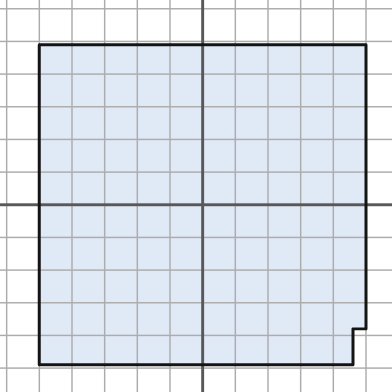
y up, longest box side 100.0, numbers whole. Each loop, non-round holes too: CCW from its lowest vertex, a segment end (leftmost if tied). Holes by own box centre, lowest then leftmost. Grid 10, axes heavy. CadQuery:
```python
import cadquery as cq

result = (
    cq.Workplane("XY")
    .moveTo(-50.0, -49.0)
    .lineTo(46.0, -49.0)
    .lineTo(46.0, -38.0)
    .lineTo(50.0, -38.0)
    .lineTo(50.0, 49.0)
    .lineTo(-50.0, 49.0)
    .close()
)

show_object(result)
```